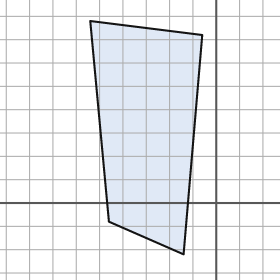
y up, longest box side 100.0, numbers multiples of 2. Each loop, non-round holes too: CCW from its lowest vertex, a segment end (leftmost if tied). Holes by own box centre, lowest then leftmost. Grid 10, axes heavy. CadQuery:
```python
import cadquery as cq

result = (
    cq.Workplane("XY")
    .moveTo(-14.0, -22.0)
    .lineTo(-6.0, 72.0)
    .lineTo(-54.0, 78.0)
    .lineTo(-46.0, -8.0)
    .close()
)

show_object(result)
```